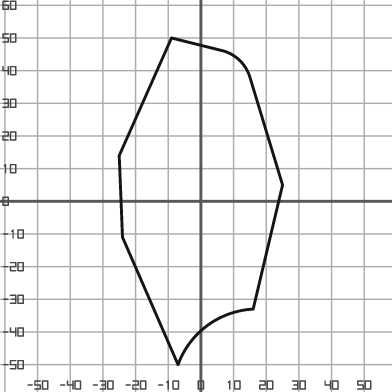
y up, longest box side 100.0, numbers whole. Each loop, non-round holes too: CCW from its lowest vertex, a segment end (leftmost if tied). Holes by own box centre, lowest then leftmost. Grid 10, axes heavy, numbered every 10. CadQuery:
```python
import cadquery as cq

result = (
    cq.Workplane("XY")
    .moveTo(-7.0, -50.0)
    .threePointArc((2.0, -38.0), (16.0, -33.0))
    .lineTo(25.0, 5.0)
    .lineTo(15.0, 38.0)
    .threePointArc((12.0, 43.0), (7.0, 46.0))
    .lineTo(-9.0, 50.0)
    .lineTo(-25.0, 14.0)
    .lineTo(-24.0, -11.0)
    .close()
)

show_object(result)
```